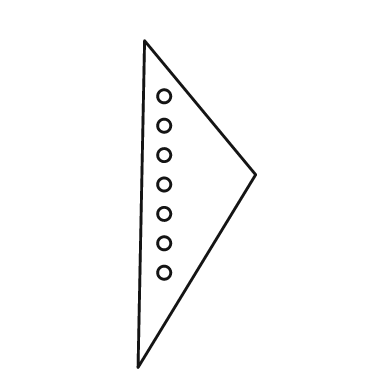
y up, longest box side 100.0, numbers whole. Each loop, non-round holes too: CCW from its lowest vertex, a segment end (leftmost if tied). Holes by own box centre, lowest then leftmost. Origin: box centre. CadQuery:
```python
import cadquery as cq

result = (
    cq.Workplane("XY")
    .moveTo(-18.0, -50.0)
    .lineTo(18.0, 9.0)
    .lineTo(-16.0, 50.0)
    .close()
    .moveTo(-10.0, -21.0)
    .circle(2.0)
    .moveTo(-10.0, -12.0)
    .circle(2.0)
    .moveTo(-10.0, -3.0)
    .circle(2.0)
    .moveTo(-10.0, 6.0)
    .circle(2.0)
    .moveTo(-10.0, 15.0)
    .circle(2.0)
    .moveTo(-10.0, 24.0)
    .circle(2.0)
    .moveTo(-10.0, 33.0)
    .circle(2.0)
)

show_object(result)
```